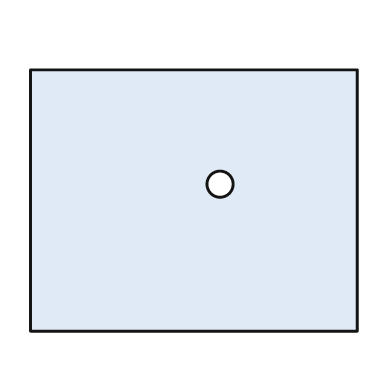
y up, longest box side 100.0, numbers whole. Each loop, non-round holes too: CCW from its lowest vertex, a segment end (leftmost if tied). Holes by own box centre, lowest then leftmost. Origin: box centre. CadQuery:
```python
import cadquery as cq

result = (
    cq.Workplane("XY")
    .moveTo(-50.0, -40.0)
    .lineTo(50.0, -40.0)
    .lineTo(50.0, 40.0)
    .lineTo(-50.0, 40.0)
    .close()
    .moveTo(8.0, 5.0)
    .circle(4.0)
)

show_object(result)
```